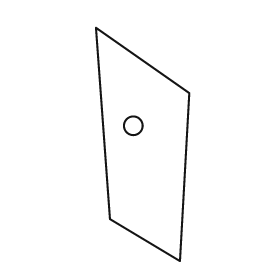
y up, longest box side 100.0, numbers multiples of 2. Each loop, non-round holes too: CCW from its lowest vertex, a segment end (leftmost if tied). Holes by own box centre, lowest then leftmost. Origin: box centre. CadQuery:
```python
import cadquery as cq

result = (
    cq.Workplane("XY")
    .moveTo(16.0, -50.0)
    .lineTo(20.0, 22.0)
    .lineTo(-20.0, 50.0)
    .lineTo(-14.0, -32.0)
    .close()
    .moveTo(-4.0, 8.0)
    .circle(4.0)
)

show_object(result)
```